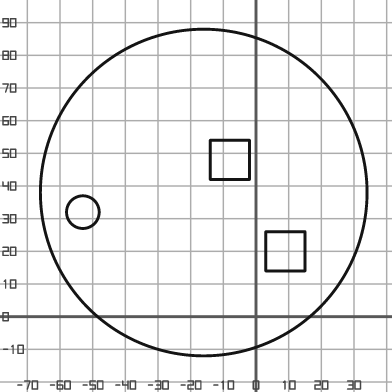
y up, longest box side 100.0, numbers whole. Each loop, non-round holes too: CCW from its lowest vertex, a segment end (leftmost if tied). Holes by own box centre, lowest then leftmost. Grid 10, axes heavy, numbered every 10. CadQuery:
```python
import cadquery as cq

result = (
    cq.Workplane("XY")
    .moveTo(-16.0, 38.0)
    .circle(50.0)
    .moveTo(3.0, 14.0)
    .lineTo(15.0, 14.0)
    .lineTo(15.0, 26.0)
    .lineTo(3.0, 26.0)
    .close()
    .moveTo(-53.0, 32.0)
    .circle(5.0)
    .moveTo(-14.0, 42.0)
    .lineTo(-2.0, 42.0)
    .lineTo(-2.0, 54.0)
    .lineTo(-14.0, 54.0)
    .close()
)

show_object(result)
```